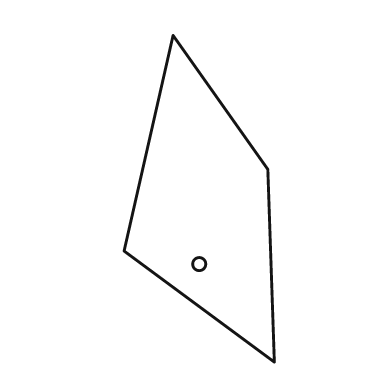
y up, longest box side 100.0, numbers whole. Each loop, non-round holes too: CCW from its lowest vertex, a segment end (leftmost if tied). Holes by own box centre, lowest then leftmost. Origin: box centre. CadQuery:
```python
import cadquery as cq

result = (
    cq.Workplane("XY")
    .moveTo(23.0, -50.0)
    .lineTo(21.0, 9.0)
    .lineTo(-8.0, 50.0)
    .lineTo(-23.0, -16.0)
    .close()
    .moveTo(0.0, -20.0)
    .circle(2.0)
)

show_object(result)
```